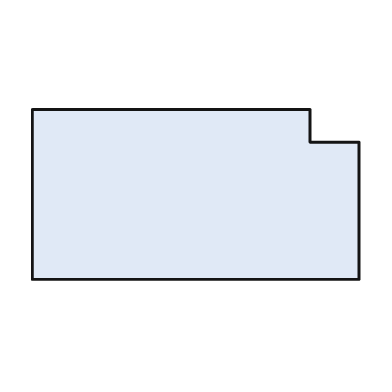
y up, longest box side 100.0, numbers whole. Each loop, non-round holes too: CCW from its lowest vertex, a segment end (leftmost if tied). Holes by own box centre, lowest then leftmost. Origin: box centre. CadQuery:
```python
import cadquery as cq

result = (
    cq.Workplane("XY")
    .moveTo(-50.0, -26.0)
    .lineTo(50.0, -26.0)
    .lineTo(50.0, 16.0)
    .lineTo(35.0, 16.0)
    .lineTo(35.0, 26.0)
    .lineTo(-50.0, 26.0)
    .close()
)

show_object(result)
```